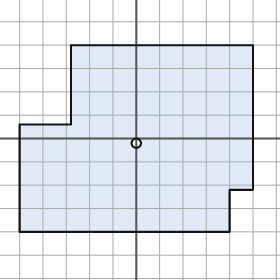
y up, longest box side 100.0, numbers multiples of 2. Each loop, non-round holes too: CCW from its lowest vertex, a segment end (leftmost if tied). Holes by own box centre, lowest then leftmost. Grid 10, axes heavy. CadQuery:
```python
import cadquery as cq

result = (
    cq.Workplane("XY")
    .moveTo(-50.0, -40.0)
    .lineTo(40.0, -40.0)
    .lineTo(40.0, -22.0)
    .lineTo(50.0, -22.0)
    .lineTo(50.0, 40.0)
    .lineTo(-28.0, 40.0)
    .lineTo(-28.0, 6.0)
    .lineTo(-50.0, 6.0)
    .close()
    .moveTo(0.0, -2.0)
    .circle(2.0)
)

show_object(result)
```